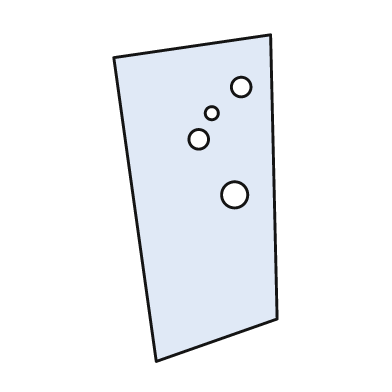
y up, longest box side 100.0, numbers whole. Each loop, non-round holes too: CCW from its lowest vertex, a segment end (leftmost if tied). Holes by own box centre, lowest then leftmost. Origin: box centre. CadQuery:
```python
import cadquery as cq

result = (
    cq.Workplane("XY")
    .moveTo(-12.0, -50.0)
    .lineTo(25.0, -37.0)
    .lineTo(23.0, 50.0)
    .lineTo(-25.0, 43.0)
    .close()
    .moveTo(12.0, 1.0)
    .circle(4.0)
    .moveTo(1.0, 18.0)
    .circle(3.0)
    .moveTo(5.0, 26.0)
    .circle(2.0)
    .moveTo(14.0, 34.0)
    .circle(3.0)
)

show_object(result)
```